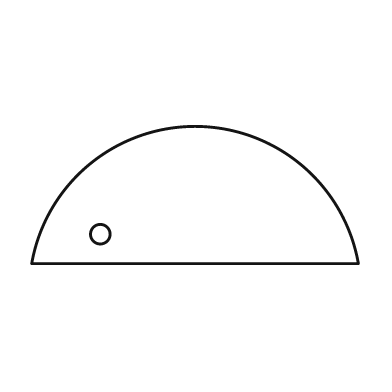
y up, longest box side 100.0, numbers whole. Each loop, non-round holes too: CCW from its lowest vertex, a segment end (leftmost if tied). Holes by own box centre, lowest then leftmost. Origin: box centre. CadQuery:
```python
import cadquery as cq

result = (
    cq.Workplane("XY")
    .moveTo(-50.0, -21.0)
    .lineTo(50.0, -21.0)
    .threePointArc((0.0, 21.0), (-50.0, -21.0))
    .close()
    .moveTo(-29.0, -12.0)
    .circle(3.0)
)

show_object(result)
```